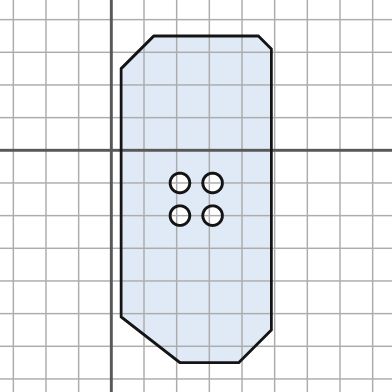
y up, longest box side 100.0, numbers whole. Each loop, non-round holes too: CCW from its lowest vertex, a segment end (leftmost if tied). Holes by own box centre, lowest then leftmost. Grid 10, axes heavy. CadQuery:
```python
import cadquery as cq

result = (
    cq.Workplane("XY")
    .moveTo(21.0, -65.0)
    .lineTo(39.0, -65.0)
    .lineTo(49.0, -55.0)
    .lineTo(49.0, 31.0)
    .lineTo(45.0, 35.0)
    .lineTo(13.0, 35.0)
    .lineTo(3.0, 25.0)
    .lineTo(3.0, -51.0)
    .close()
    .moveTo(21.0, -20.0)
    .circle(3.0)
    .moveTo(31.0, -20.0)
    .circle(3.0)
    .moveTo(21.0, -10.0)
    .circle(3.0)
    .moveTo(31.0, -10.0)
    .circle(3.0)
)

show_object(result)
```